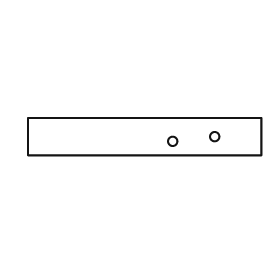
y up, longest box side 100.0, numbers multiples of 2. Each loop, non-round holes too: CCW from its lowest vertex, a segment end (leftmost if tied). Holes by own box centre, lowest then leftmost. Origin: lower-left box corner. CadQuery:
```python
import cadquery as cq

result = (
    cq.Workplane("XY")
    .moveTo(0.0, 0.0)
    .lineTo(100.0, 0.0)
    .lineTo(100.0, 16.0)
    .lineTo(0.0, 16.0)
    .close()
    .moveTo(62.0, 6.0)
    .circle(2.0)
    .moveTo(80.0, 8.0)
    .circle(2.0)
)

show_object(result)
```